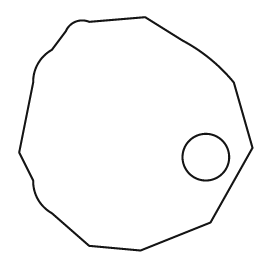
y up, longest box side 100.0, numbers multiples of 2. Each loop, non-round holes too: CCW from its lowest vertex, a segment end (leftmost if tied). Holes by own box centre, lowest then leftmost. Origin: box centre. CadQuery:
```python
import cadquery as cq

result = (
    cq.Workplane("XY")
    .moveTo(2.0, -50.0)
    .lineTo(32.0, -38.0)
    .lineTo(50.0, -6.0)
    .lineTo(42.0, 22.0)
    .threePointArc((32.0, 32.0), (20.0, 40.0))
    .lineTo(4.0, 50.0)
    .lineTo(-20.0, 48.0)
    .threePointArc((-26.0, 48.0), (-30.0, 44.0))
    .lineTo(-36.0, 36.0)
    .threePointArc((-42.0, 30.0), (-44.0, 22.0))
    .lineTo(-50.0, -8.0)
    .lineTo(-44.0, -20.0)
    .threePointArc((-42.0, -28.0), (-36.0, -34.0))
    .lineTo(-20.0, -48.0)
    .close()
    .moveTo(30.0, -10.0)
    .circle(10.0)
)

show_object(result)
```